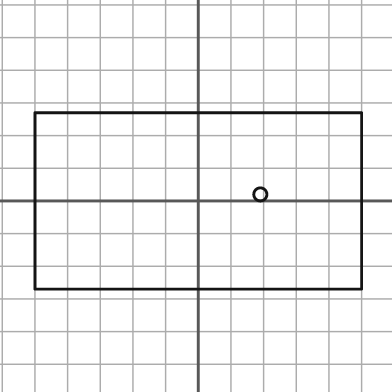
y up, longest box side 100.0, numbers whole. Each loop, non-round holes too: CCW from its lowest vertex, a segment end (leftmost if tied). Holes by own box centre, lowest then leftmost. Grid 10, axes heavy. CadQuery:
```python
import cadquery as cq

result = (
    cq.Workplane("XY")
    .moveTo(-50.0, -27.0)
    .lineTo(50.0, -27.0)
    .lineTo(50.0, 27.0)
    .lineTo(-50.0, 27.0)
    .close()
    .moveTo(19.0, 2.0)
    .circle(2.0)
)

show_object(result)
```